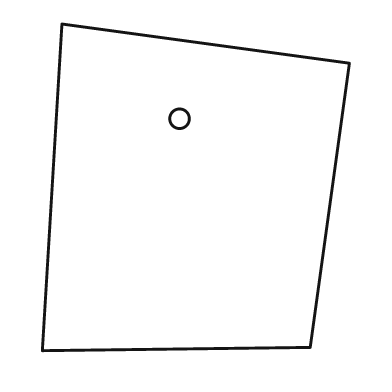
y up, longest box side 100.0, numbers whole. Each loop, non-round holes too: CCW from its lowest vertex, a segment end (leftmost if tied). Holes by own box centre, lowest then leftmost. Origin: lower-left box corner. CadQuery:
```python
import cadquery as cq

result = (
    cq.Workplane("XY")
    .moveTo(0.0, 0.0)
    .lineTo(82.0, 1.0)
    .lineTo(94.0, 88.0)
    .lineTo(6.0, 100.0)
    .close()
    .moveTo(42.0, 71.0)
    .circle(3.0)
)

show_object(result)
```